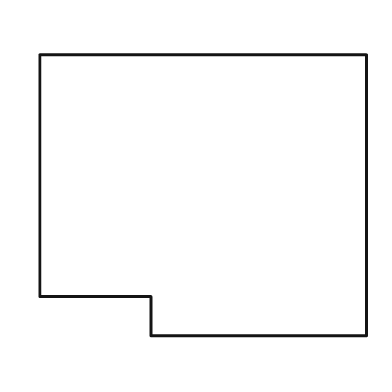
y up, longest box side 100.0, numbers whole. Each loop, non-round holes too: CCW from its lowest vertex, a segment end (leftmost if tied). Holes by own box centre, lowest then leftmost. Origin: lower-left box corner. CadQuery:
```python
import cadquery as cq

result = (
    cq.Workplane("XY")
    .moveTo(34.0, 0.0)
    .lineTo(100.0, 0.0)
    .lineTo(100.0, 86.0)
    .lineTo(0.0, 86.0)
    .lineTo(0.0, 12.0)
    .lineTo(34.0, 12.0)
    .close()
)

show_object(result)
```